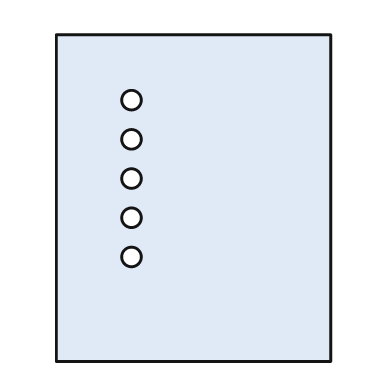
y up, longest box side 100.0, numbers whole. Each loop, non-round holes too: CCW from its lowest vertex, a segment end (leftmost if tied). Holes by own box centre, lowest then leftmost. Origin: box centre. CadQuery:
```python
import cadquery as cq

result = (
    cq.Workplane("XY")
    .moveTo(-42.0, -50.0)
    .lineTo(42.0, -50.0)
    .lineTo(42.0, 50.0)
    .lineTo(-42.0, 50.0)
    .close()
    .moveTo(-19.0, -18.0)
    .circle(3.0)
    .moveTo(-19.0, -6.0)
    .circle(3.0)
    .moveTo(-19.0, 6.0)
    .circle(3.0)
    .moveTo(-19.0, 18.0)
    .circle(3.0)
    .moveTo(-19.0, 30.0)
    .circle(3.0)
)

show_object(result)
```